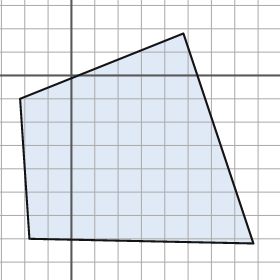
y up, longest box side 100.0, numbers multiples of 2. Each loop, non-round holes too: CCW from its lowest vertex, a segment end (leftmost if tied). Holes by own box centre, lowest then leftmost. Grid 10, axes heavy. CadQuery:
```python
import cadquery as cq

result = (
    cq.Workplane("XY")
    .moveTo(78.0, -72.0)
    .lineTo(48.0, 18.0)
    .lineTo(-22.0, -10.0)
    .lineTo(-18.0, -70.0)
    .close()
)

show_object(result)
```